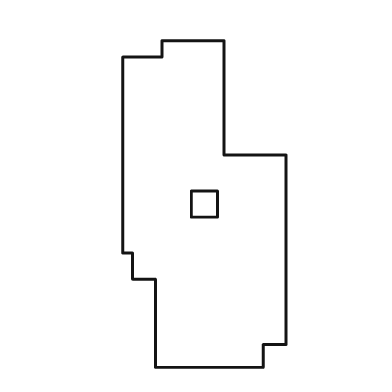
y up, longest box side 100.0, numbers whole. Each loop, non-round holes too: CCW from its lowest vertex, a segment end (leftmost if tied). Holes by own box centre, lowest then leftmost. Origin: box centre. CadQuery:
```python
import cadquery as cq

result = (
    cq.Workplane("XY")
    .moveTo(-15.0, -50.0)
    .lineTo(18.0, -50.0)
    .lineTo(18.0, -43.0)
    .lineTo(25.0, -43.0)
    .lineTo(25.0, 15.0)
    .lineTo(6.0, 15.0)
    .lineTo(6.0, 50.0)
    .lineTo(-13.0, 50.0)
    .lineTo(-13.0, 45.0)
    .lineTo(-25.0, 45.0)
    .lineTo(-25.0, -15.0)
    .lineTo(-22.0, -15.0)
    .lineTo(-22.0, -23.0)
    .lineTo(-15.0, -23.0)
    .close()
    .moveTo(-4.0, -4.0)
    .lineTo(4.0, -4.0)
    .lineTo(4.0, 4.0)
    .lineTo(-4.0, 4.0)
    .close()
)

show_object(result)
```